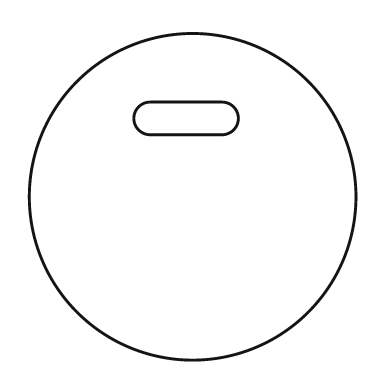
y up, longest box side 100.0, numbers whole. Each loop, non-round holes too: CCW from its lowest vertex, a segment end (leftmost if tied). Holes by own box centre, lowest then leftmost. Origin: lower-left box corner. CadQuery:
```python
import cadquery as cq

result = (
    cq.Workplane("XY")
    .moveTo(50.0, 50.0)
    .circle(50.0)
    .moveTo(37.0, 69.0)
    .lineTo(59.0, 69.0)
    .threePointArc((64.0, 74.0), (59.0, 79.0))
    .lineTo(37.0, 79.0)
    .threePointArc((32.0, 74.0), (37.0, 69.0))
    .close()
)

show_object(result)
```